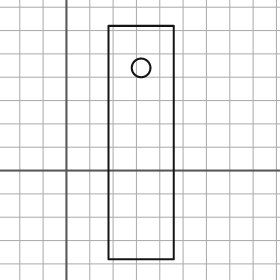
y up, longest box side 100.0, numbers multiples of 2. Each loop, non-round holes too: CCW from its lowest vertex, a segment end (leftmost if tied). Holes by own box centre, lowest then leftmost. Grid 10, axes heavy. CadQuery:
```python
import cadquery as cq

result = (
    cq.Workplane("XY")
    .moveTo(18.0, -38.0)
    .lineTo(46.0, -38.0)
    .lineTo(46.0, 62.0)
    .lineTo(18.0, 62.0)
    .close()
    .moveTo(32.0, 44.0)
    .circle(4.0)
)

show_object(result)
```